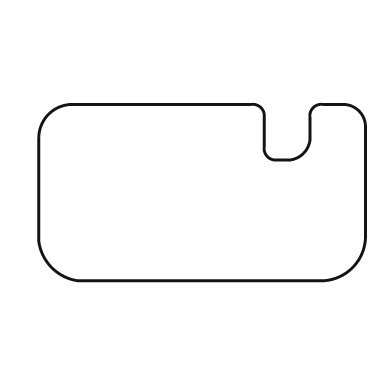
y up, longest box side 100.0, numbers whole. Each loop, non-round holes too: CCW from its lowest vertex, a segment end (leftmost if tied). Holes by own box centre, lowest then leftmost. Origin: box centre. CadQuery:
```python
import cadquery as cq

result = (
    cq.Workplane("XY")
    .moveTo(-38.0, -27.0)
    .lineTo(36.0, -27.0)
    .threePointArc((46.0, -23.0), (50.0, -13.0))
    .lineTo(50.0, 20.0)
    .threePointArc((48.0, 25.0), (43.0, 27.0))
    .lineTo(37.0, 27.0)
    .threePointArc((34.0, 26.0), (33.0, 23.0))
    .lineTo(33.0, 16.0)
    .threePointArc((31.0, 12.0), (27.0, 10.0))
    .lineTo(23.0, 10.0)
    .threePointArc((20.0, 11.0), (19.0, 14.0))
    .lineTo(19.0, 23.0)
    .threePointArc((18.0, 26.0), (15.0, 27.0))
    .lineTo(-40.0, 27.0)
    .threePointArc((-47.0, 24.0), (-50.0, 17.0))
    .lineTo(-50.0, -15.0)
    .threePointArc((-46.0, -23.0), (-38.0, -27.0))
    .close()
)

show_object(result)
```